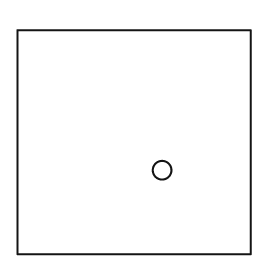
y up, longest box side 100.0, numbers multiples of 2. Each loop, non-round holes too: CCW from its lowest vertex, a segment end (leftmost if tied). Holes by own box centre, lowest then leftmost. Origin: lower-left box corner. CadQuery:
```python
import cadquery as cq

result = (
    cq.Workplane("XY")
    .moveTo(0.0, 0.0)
    .lineTo(100.0, 0.0)
    .lineTo(100.0, 96.0)
    .lineTo(0.0, 96.0)
    .close()
    .moveTo(62.0, 36.0)
    .circle(4.0)
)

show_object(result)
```